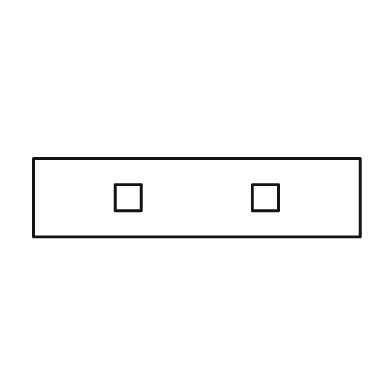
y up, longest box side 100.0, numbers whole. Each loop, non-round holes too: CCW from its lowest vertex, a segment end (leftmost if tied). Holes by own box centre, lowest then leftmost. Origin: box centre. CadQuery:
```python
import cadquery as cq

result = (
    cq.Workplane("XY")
    .moveTo(-50.0, -12.0)
    .lineTo(50.0, -12.0)
    .lineTo(50.0, 12.0)
    .lineTo(-50.0, 12.0)
    .close()
    .moveTo(-25.0, -4.0)
    .lineTo(-17.0, -4.0)
    .lineTo(-17.0, 4.0)
    .lineTo(-25.0, 4.0)
    .close()
    .moveTo(17.0, -4.0)
    .lineTo(25.0, -4.0)
    .lineTo(25.0, 4.0)
    .lineTo(17.0, 4.0)
    .close()
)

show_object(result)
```